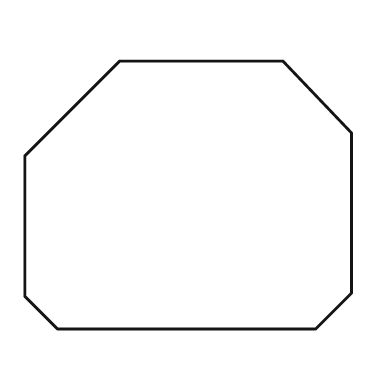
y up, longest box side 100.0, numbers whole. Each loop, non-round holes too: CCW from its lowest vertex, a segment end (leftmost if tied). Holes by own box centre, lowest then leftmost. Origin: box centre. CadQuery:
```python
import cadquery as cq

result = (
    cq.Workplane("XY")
    .moveTo(-40.0, -41.0)
    .lineTo(39.0, -41.0)
    .lineTo(50.0, -30.0)
    .lineTo(50.0, 19.0)
    .lineTo(29.0, 41.0)
    .lineTo(-21.0, 41.0)
    .lineTo(-50.0, 12.0)
    .lineTo(-50.0, -31.0)
    .close()
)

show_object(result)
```